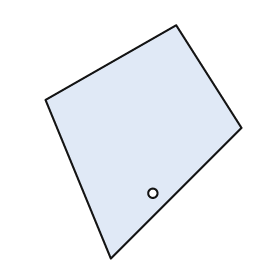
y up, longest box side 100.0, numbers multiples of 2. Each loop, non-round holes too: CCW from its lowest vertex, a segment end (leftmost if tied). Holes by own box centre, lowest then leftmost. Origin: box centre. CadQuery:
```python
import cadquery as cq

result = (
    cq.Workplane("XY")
    .moveTo(-14.0, -50.0)
    .lineTo(42.0, 6.0)
    .lineTo(14.0, 50.0)
    .lineTo(-42.0, 18.0)
    .close()
    .moveTo(4.0, -22.0)
    .circle(2.0)
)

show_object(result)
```